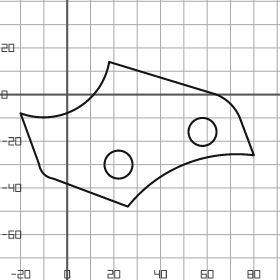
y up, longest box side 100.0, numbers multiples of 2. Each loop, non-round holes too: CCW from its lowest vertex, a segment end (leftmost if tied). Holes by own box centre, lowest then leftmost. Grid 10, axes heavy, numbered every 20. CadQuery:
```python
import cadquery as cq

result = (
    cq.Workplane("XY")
    .moveTo(26.0, -48.0)
    .threePointArc((50.0, -30.0), (80.0, -26.0))
    .lineTo(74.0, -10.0)
    .threePointArc((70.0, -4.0), (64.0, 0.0))
    .lineTo(18.0, 14.0)
    .threePointArc((4.0, -6.0), (-20.0, -8.0))
    .lineTo(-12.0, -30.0)
    .threePointArc((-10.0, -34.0), (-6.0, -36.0))
    .close()
    .moveTo(22.0, -30.0)
    .circle(6.0)
    .moveTo(58.0, -16.0)
    .circle(6.0)
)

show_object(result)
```